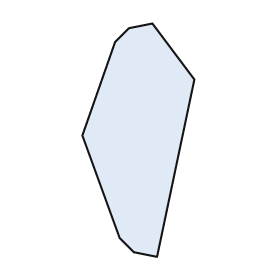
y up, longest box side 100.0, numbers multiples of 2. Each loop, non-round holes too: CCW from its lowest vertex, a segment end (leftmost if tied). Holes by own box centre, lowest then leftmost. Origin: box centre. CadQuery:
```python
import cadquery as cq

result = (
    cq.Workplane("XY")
    .moveTo(8.0, -50.0)
    .lineTo(24.0, 26.0)
    .lineTo(6.0, 50.0)
    .lineTo(-4.0, 48.0)
    .lineTo(-10.0, 42.0)
    .lineTo(-24.0, 2.0)
    .lineTo(-8.0, -42.0)
    .lineTo(-2.0, -48.0)
    .close()
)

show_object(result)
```